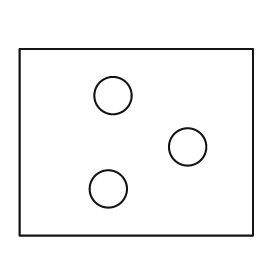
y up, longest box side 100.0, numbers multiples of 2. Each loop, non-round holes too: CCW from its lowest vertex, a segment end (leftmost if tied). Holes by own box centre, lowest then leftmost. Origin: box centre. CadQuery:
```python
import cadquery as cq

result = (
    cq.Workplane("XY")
    .moveTo(-50.0, -40.0)
    .lineTo(50.0, -40.0)
    .lineTo(50.0, 40.0)
    .lineTo(-50.0, 40.0)
    .close()
    .moveTo(-12.0, -20.0)
    .circle(8.0)
    .moveTo(22.0, -2.0)
    .circle(8.0)
    .moveTo(-10.0, 20.0)
    .circle(8.0)
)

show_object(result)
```